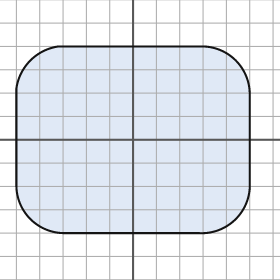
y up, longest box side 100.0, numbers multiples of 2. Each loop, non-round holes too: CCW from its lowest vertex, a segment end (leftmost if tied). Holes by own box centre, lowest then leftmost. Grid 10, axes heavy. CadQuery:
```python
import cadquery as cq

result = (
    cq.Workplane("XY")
    .moveTo(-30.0, -40.0)
    .lineTo(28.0, -40.0)
    .threePointArc((44.0, -34.0), (50.0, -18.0))
    .lineTo(50.0, 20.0)
    .threePointArc((44.0, 34.0), (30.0, 40.0))
    .lineTo(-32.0, 40.0)
    .threePointArc((-44.0, 34.0), (-50.0, 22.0))
    .lineTo(-50.0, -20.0)
    .threePointArc((-44.0, -34.0), (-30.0, -40.0))
    .close()
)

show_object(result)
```